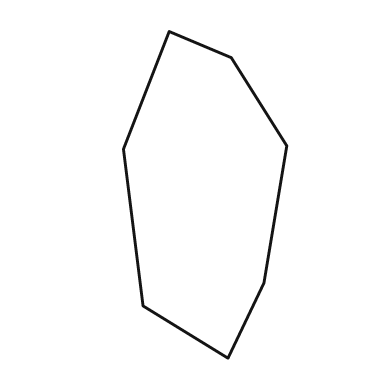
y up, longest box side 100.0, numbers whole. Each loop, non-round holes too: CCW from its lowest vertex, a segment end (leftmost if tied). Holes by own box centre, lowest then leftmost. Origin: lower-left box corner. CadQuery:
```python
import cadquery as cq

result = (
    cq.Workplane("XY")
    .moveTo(32.0, 0.0)
    .lineTo(43.0, 23.0)
    .lineTo(50.0, 65.0)
    .lineTo(33.0, 92.0)
    .lineTo(14.0, 100.0)
    .lineTo(0.0, 64.0)
    .lineTo(6.0, 16.0)
    .close()
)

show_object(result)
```